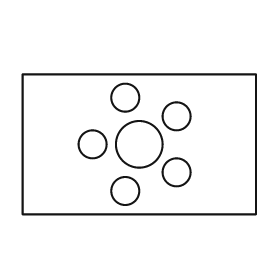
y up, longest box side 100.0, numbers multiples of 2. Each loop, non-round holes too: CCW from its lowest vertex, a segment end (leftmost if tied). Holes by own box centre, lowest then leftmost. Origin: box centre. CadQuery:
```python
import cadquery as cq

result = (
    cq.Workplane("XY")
    .moveTo(-50.0, -30.0)
    .lineTo(50.0, -30.0)
    .lineTo(50.0, 30.0)
    .lineTo(-50.0, 30.0)
    .close()
    .moveTo(-6.0, -20.0)
    .circle(6.0)
    .moveTo(16.0, -12.0)
    .circle(6.0)
    .moveTo(-20.0, 0.0)
    .circle(6.0)
    .moveTo(0.0, 0.0)
    .circle(10.0)
    .moveTo(16.0, 12.0)
    .circle(6.0)
    .moveTo(-6.0, 20.0)
    .circle(6.0)
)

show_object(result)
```